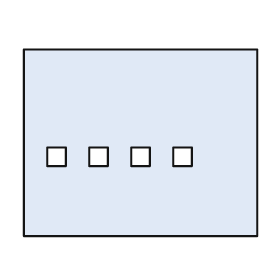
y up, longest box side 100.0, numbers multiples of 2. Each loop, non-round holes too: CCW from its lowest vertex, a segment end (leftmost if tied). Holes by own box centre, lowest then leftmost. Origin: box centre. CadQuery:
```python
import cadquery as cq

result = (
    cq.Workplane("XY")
    .moveTo(-50.0, -40.0)
    .lineTo(50.0, -40.0)
    .lineTo(50.0, 40.0)
    .lineTo(-50.0, 40.0)
    .close()
    .moveTo(-40.0, -10.0)
    .lineTo(-32.0, -10.0)
    .lineTo(-32.0, -2.0)
    .lineTo(-40.0, -2.0)
    .close()
    .moveTo(-22.0, -10.0)
    .lineTo(-14.0, -10.0)
    .lineTo(-14.0, -2.0)
    .lineTo(-22.0, -2.0)
    .close()
    .moveTo(-4.0, -10.0)
    .lineTo(4.0, -10.0)
    .lineTo(4.0, -2.0)
    .lineTo(-4.0, -2.0)
    .close()
    .moveTo(14.0, -10.0)
    .lineTo(22.0, -10.0)
    .lineTo(22.0, -2.0)
    .lineTo(14.0, -2.0)
    .close()
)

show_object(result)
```